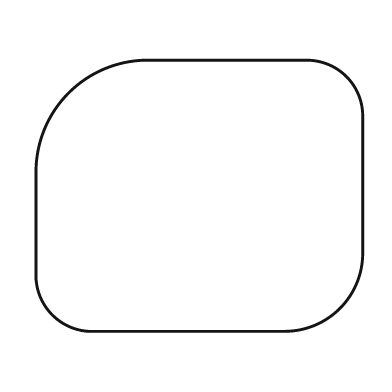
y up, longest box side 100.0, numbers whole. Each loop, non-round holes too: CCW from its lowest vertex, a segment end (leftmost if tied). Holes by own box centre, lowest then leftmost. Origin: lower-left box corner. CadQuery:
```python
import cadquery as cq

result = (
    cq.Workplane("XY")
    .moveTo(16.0, 0.0)
    .lineTo(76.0, 0.0)
    .threePointArc((93.0, 7.0), (100.0, 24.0))
    .lineTo(100.0, 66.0)
    .threePointArc((95.0, 78.0), (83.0, 83.0))
    .lineTo(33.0, 83.0)
    .threePointArc((10.0, 73.0), (0.0, 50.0))
    .lineTo(0.0, 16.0)
    .threePointArc((5.0, 5.0), (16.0, 0.0))
    .close()
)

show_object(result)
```